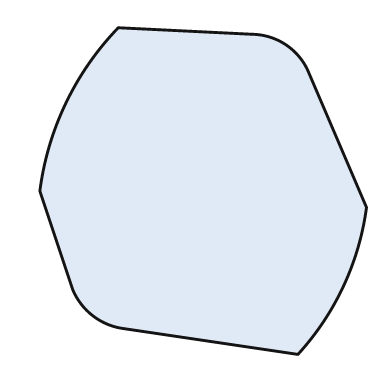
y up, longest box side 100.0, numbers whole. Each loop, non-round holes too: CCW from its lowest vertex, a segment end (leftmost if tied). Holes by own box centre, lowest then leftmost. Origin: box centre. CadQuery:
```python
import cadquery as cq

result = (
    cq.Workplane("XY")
    .moveTo(29.0, -50.0)
    .threePointArc((43.0, -29.0), (50.0, -5.0))
    .lineTo(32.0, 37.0)
    .threePointArc((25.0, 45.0), (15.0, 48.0))
    .lineTo(-26.0, 50.0)
    .threePointArc((-42.0, 27.0), (-50.0, 0.0))
    .lineTo(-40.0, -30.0)
    .threePointArc((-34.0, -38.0), (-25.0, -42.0))
    .close()
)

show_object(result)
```